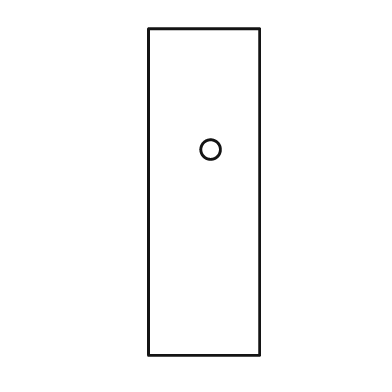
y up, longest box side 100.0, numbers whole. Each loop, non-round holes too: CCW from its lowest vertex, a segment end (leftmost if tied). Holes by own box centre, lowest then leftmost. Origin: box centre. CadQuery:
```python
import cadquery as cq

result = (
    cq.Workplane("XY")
    .moveTo(-17.0, -50.0)
    .lineTo(17.0, -50.0)
    .lineTo(17.0, 50.0)
    .lineTo(-17.0, 50.0)
    .close()
    .moveTo(2.0, 13.0)
    .circle(3.0)
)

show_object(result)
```